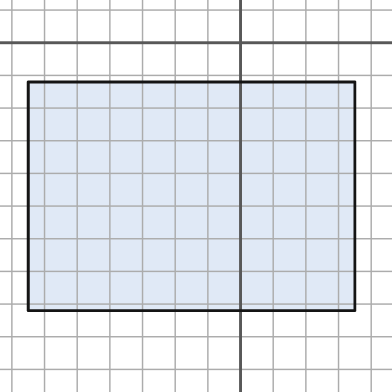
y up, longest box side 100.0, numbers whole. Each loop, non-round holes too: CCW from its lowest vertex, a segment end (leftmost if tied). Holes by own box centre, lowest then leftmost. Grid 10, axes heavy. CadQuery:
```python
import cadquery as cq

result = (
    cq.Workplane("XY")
    .moveTo(-65.0, -82.0)
    .lineTo(35.0, -82.0)
    .lineTo(35.0, -12.0)
    .lineTo(-65.0, -12.0)
    .close()
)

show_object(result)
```